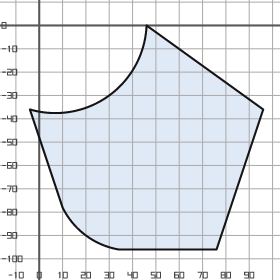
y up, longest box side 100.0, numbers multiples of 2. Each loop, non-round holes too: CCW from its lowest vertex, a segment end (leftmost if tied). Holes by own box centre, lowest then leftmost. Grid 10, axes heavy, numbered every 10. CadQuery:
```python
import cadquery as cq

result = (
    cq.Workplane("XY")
    .moveTo(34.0, -96.0)
    .lineTo(76.0, -96.0)
    .lineTo(96.0, -36.0)
    .lineTo(46.0, 0.0)
    .threePointArc((30.0, -30.0), (-4.0, -36.0))
    .lineTo(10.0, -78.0)
    .threePointArc((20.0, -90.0), (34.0, -96.0))
    .close()
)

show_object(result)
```